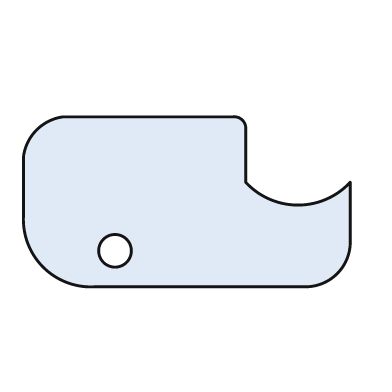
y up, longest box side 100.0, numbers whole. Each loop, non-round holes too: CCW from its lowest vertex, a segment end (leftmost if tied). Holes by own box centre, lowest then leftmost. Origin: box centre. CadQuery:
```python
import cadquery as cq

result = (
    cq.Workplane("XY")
    .moveTo(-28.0, -26.0)
    .lineTo(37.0, -26.0)
    .threePointArc((46.0, -22.0), (50.0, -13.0))
    .lineTo(50.0, 6.0)
    .threePointArc((34.0, -1.0), (18.0, 6.0))
    .lineTo(18.0, 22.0)
    .threePointArc((17.0, 25.0), (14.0, 26.0))
    .lineTo(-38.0, 26.0)
    .threePointArc((-46.0, 22.0), (-50.0, 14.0))
    .lineTo(-50.0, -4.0)
    .threePointArc((-44.0, -20.0), (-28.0, -26.0))
    .close()
    .moveTo(-22.0, -15.0)
    .circle(5.0)
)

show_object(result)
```